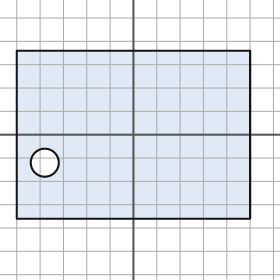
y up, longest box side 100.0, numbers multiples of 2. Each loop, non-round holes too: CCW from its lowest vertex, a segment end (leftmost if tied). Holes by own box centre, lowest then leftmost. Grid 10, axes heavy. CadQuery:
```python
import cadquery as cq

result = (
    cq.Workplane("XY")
    .moveTo(-50.0, -36.0)
    .lineTo(50.0, -36.0)
    .lineTo(50.0, 36.0)
    .lineTo(-50.0, 36.0)
    .close()
    .moveTo(-38.0, -12.0)
    .circle(6.0)
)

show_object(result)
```